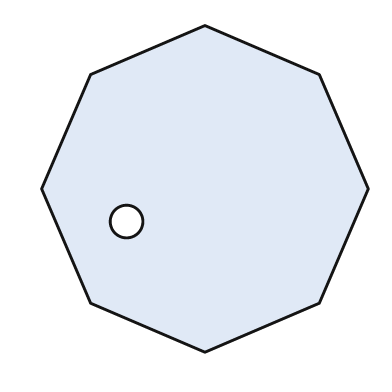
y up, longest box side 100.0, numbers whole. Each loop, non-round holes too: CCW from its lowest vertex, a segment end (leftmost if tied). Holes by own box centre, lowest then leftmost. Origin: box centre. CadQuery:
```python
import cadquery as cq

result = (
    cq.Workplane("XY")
    .moveTo(0.0, -50.0)
    .lineTo(35.0, -35.0)
    .lineTo(50.0, 0.0)
    .lineTo(35.0, 35.0)
    .lineTo(0.0, 50.0)
    .lineTo(-35.0, 35.0)
    .lineTo(-50.0, 0.0)
    .lineTo(-35.0, -35.0)
    .close()
    .moveTo(-24.0, -10.0)
    .circle(5.0)
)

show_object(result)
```